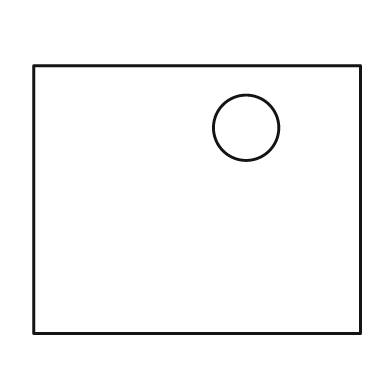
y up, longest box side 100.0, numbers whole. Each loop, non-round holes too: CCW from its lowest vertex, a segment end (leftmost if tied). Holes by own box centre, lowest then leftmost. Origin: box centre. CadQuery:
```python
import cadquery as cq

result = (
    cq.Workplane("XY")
    .moveTo(-50.0, -41.0)
    .lineTo(50.0, -41.0)
    .lineTo(50.0, 41.0)
    .lineTo(-50.0, 41.0)
    .close()
    .moveTo(15.0, 22.0)
    .circle(10.0)
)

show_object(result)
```